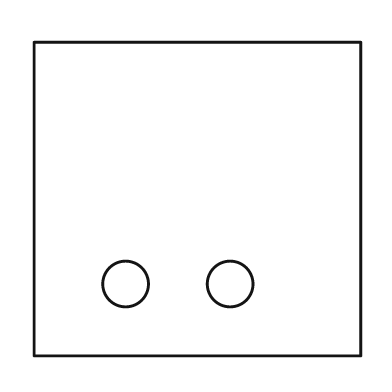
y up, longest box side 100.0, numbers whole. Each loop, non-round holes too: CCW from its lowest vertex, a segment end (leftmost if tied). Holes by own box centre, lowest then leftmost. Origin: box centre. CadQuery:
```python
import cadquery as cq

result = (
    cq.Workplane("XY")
    .moveTo(-50.0, -48.0)
    .lineTo(50.0, -48.0)
    .lineTo(50.0, 48.0)
    .lineTo(-50.0, 48.0)
    .close()
    .moveTo(-22.0, -26.0)
    .circle(7.0)
    .moveTo(10.0, -26.0)
    .circle(7.0)
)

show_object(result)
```